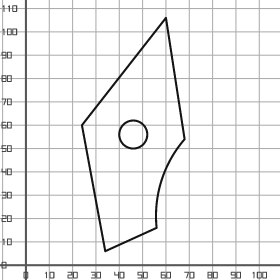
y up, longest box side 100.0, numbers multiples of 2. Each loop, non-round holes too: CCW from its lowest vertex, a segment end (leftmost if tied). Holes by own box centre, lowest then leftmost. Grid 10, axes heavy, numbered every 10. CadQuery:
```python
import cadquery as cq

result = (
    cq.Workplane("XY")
    .moveTo(34.0, 6.0)
    .lineTo(56.0, 16.0)
    .threePointArc((58.0, 36.0), (68.0, 54.0))
    .lineTo(60.0, 106.0)
    .lineTo(24.0, 60.0)
    .close()
    .moveTo(46.0, 56.0)
    .circle(6.0)
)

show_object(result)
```